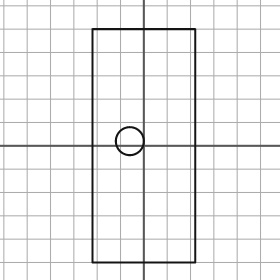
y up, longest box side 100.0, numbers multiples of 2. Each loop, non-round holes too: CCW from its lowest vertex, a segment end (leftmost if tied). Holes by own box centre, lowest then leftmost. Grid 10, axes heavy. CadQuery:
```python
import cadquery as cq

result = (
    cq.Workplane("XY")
    .moveTo(-22.0, -50.0)
    .lineTo(22.0, -50.0)
    .lineTo(22.0, 50.0)
    .lineTo(-22.0, 50.0)
    .close()
    .moveTo(-6.0, 2.0)
    .circle(6.0)
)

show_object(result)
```